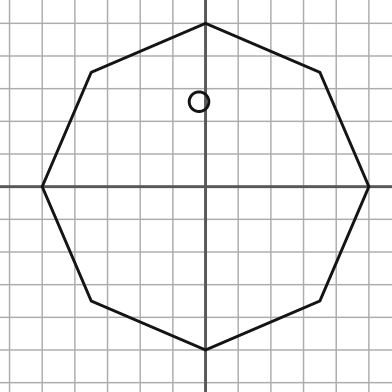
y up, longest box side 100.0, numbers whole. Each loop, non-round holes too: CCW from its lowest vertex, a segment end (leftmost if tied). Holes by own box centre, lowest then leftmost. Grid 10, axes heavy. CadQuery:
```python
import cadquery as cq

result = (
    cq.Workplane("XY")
    .moveTo(0.0, -50.0)
    .lineTo(35.0, -35.0)
    .lineTo(50.0, 0.0)
    .lineTo(35.0, 35.0)
    .lineTo(0.0, 50.0)
    .lineTo(-35.0, 35.0)
    .lineTo(-50.0, 0.0)
    .lineTo(-35.0, -35.0)
    .close()
    .moveTo(-2.0, 26.0)
    .circle(3.0)
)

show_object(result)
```